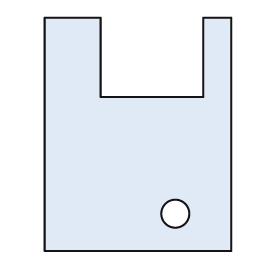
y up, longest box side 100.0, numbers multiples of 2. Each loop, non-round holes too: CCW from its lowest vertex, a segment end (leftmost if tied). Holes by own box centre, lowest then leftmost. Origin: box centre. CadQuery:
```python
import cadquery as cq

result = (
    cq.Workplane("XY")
    .moveTo(-40.0, -50.0)
    .lineTo(40.0, -50.0)
    .lineTo(40.0, 50.0)
    .lineTo(28.0, 50.0)
    .lineTo(28.0, 16.0)
    .lineTo(-16.0, 16.0)
    .lineTo(-16.0, 50.0)
    .lineTo(-40.0, 50.0)
    .close()
    .moveTo(16.0, -34.0)
    .circle(6.0)
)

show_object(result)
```